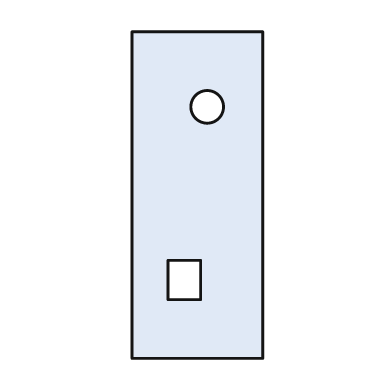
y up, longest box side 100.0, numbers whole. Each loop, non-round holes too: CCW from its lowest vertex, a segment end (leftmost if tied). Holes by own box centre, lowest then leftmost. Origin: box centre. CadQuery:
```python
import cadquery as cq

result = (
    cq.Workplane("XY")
    .moveTo(-20.0, -50.0)
    .lineTo(20.0, -50.0)
    .lineTo(20.0, 50.0)
    .lineTo(-20.0, 50.0)
    .close()
    .moveTo(-9.0, -32.0)
    .lineTo(1.0, -32.0)
    .lineTo(1.0, -20.0)
    .lineTo(-9.0, -20.0)
    .close()
    .moveTo(3.0, 27.0)
    .circle(5.0)
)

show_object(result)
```